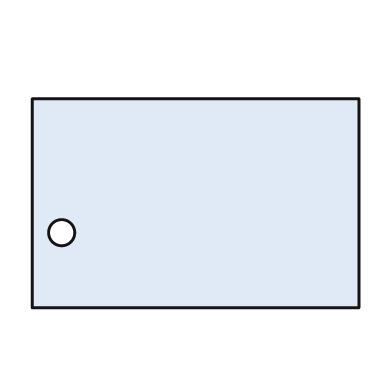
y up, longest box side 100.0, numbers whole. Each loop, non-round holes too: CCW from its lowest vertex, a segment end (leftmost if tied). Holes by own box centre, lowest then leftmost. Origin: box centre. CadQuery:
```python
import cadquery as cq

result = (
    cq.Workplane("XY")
    .moveTo(-50.0, -32.0)
    .lineTo(50.0, -32.0)
    .lineTo(50.0, 32.0)
    .lineTo(-50.0, 32.0)
    .close()
    .moveTo(-41.0, -9.0)
    .circle(4.0)
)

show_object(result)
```